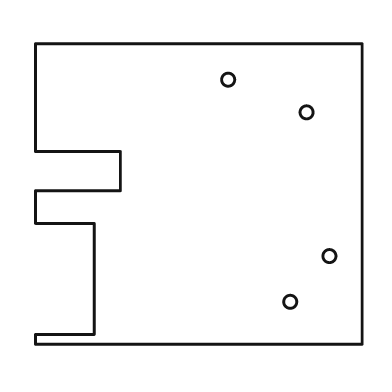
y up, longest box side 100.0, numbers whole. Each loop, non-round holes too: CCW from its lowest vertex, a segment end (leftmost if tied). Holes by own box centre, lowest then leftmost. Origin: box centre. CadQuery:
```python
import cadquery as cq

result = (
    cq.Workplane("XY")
    .moveTo(-50.0, -46.0)
    .lineTo(50.0, -46.0)
    .lineTo(50.0, 46.0)
    .lineTo(-50.0, 46.0)
    .lineTo(-50.0, 13.0)
    .lineTo(-24.0, 13.0)
    .lineTo(-24.0, 1.0)
    .lineTo(-50.0, 1.0)
    .lineTo(-50.0, -9.0)
    .lineTo(-32.0, -9.0)
    .lineTo(-32.0, -43.0)
    .lineTo(-50.0, -43.0)
    .close()
    .moveTo(28.0, -33.0)
    .circle(2.0)
    .moveTo(40.0, -19.0)
    .circle(2.0)
    .moveTo(33.0, 25.0)
    .circle(2.0)
    .moveTo(9.0, 35.0)
    .circle(2.0)
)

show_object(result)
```